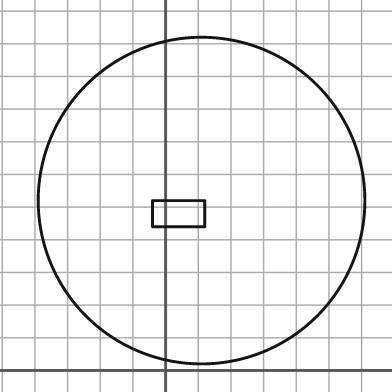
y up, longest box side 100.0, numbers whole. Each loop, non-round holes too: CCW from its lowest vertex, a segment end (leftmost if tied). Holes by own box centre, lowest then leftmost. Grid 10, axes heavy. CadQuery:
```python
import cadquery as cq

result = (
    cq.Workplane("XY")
    .moveTo(11.0, 52.0)
    .circle(50.0)
    .moveTo(-4.0, 44.0)
    .lineTo(12.0, 44.0)
    .lineTo(12.0, 52.0)
    .lineTo(-4.0, 52.0)
    .close()
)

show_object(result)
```